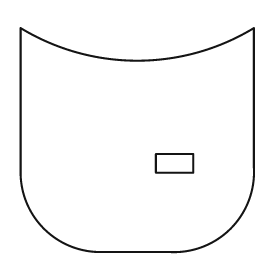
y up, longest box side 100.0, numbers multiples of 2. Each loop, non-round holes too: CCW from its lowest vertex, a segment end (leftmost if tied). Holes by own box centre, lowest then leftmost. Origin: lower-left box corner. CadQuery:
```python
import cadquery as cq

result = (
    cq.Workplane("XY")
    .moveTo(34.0, 0.0)
    .lineTo(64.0, 0.0)
    .threePointArc((90.0, 10.0), (100.0, 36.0))
    .lineTo(100.0, 96.0)
    .threePointArc((50.0, 82.0), (0.0, 96.0))
    .lineTo(0.0, 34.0)
    .threePointArc((10.0, 10.0), (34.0, 0.0))
    .close()
    .moveTo(58.0, 34.0)
    .lineTo(74.0, 34.0)
    .lineTo(74.0, 42.0)
    .lineTo(58.0, 42.0)
    .close()
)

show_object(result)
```